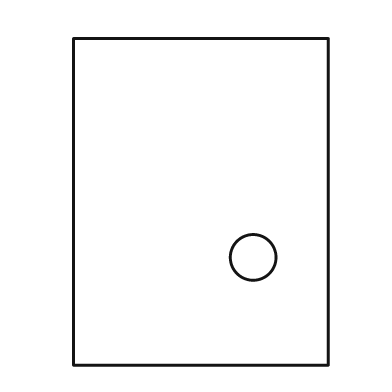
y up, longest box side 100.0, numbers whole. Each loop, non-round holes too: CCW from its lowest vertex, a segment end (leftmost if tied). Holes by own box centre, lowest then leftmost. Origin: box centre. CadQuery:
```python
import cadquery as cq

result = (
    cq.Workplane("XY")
    .moveTo(-39.0, -50.0)
    .lineTo(39.0, -50.0)
    .lineTo(39.0, 50.0)
    .lineTo(-39.0, 50.0)
    .close()
    .moveTo(16.0, -17.0)
    .circle(7.0)
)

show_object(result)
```